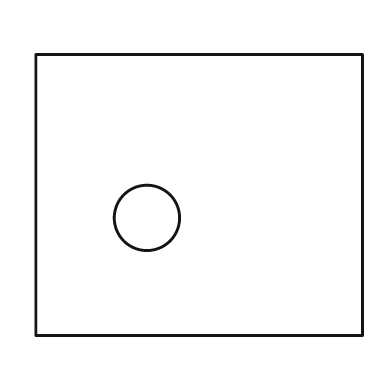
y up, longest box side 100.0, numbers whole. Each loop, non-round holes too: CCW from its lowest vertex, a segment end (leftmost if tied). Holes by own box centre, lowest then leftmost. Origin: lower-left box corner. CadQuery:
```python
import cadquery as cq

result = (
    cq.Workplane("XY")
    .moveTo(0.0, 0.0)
    .lineTo(100.0, 0.0)
    .lineTo(100.0, 86.0)
    .lineTo(0.0, 86.0)
    .close()
    .moveTo(34.0, 36.0)
    .circle(10.0)
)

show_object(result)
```